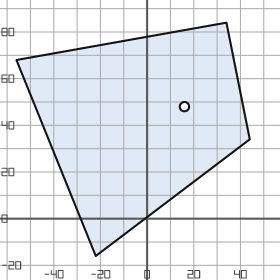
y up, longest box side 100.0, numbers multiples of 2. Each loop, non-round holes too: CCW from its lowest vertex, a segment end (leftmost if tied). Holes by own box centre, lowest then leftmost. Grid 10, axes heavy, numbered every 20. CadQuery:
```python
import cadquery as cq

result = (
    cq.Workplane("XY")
    .moveTo(-22.0, -16.0)
    .lineTo(44.0, 34.0)
    .lineTo(34.0, 84.0)
    .lineTo(-56.0, 68.0)
    .close()
    .moveTo(16.0, 48.0)
    .circle(2.0)
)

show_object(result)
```